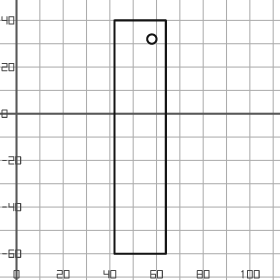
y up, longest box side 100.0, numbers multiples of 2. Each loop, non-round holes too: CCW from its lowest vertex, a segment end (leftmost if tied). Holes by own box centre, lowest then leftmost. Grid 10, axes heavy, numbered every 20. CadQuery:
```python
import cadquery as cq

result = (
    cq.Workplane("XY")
    .moveTo(42.0, -60.0)
    .lineTo(64.0, -60.0)
    .lineTo(64.0, 40.0)
    .lineTo(42.0, 40.0)
    .close()
    .moveTo(58.0, 32.0)
    .circle(2.0)
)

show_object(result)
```